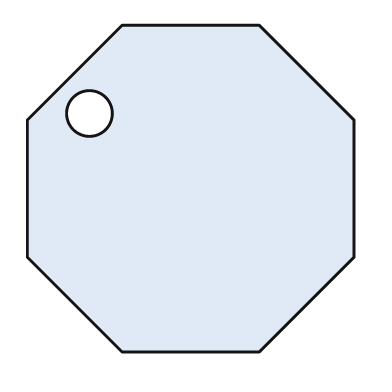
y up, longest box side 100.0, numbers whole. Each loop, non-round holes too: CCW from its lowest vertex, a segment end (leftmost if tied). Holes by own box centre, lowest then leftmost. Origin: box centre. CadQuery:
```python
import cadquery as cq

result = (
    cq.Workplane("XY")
    .moveTo(-21.0, -50.0)
    .lineTo(21.0, -50.0)
    .lineTo(50.0, -21.0)
    .lineTo(50.0, 21.0)
    .lineTo(21.0, 50.0)
    .lineTo(-21.0, 50.0)
    .lineTo(-50.0, 21.0)
    .lineTo(-50.0, -21.0)
    .close()
    .moveTo(-31.0, 23.0)
    .circle(7.0)
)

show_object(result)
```